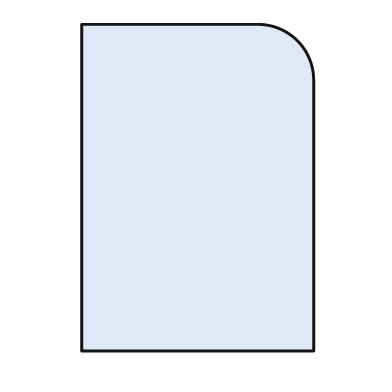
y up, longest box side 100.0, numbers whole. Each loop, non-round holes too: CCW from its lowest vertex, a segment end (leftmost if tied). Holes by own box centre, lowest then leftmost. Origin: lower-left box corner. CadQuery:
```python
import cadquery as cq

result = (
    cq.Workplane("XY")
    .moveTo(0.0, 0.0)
    .lineTo(71.0, 0.0)
    .lineTo(71.0, 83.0)
    .threePointArc((66.0, 95.0), (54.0, 100.0))
    .lineTo(0.0, 100.0)
    .close()
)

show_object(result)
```